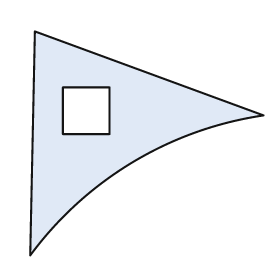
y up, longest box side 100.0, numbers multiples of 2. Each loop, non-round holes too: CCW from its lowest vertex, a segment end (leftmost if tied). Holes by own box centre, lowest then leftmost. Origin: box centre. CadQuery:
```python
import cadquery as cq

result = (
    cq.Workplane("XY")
    .moveTo(-50.0, -48.0)
    .threePointArc((-6.0, -8.0), (50.0, 12.0))
    .lineTo(-48.0, 48.0)
    .close()
    .moveTo(-36.0, 4.0)
    .lineTo(-16.0, 4.0)
    .lineTo(-16.0, 24.0)
    .lineTo(-36.0, 24.0)
    .close()
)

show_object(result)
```